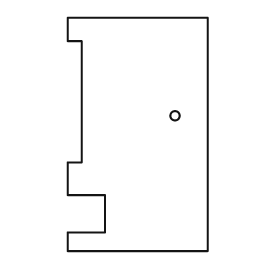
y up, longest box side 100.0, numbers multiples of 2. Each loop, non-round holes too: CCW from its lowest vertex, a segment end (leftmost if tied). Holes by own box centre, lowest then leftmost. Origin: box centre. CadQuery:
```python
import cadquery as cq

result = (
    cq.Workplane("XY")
    .moveTo(-30.0, -50.0)
    .lineTo(30.0, -50.0)
    .lineTo(30.0, 50.0)
    .lineTo(-30.0, 50.0)
    .lineTo(-30.0, 40.0)
    .lineTo(-24.0, 40.0)
    .lineTo(-24.0, -12.0)
    .lineTo(-30.0, -12.0)
    .lineTo(-30.0, -26.0)
    .lineTo(-14.0, -26.0)
    .lineTo(-14.0, -42.0)
    .lineTo(-30.0, -42.0)
    .close()
    .moveTo(16.0, 8.0)
    .circle(2.0)
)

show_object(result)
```